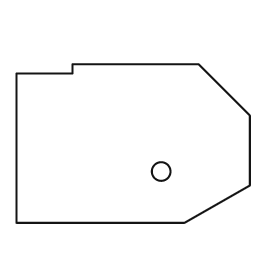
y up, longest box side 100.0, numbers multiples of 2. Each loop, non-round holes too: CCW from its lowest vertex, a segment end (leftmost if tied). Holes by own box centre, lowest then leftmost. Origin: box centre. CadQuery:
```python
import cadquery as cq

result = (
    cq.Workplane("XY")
    .moveTo(-50.0, -34.0)
    .lineTo(22.0, -34.0)
    .lineTo(50.0, -18.0)
    .lineTo(50.0, 12.0)
    .lineTo(28.0, 34.0)
    .lineTo(-26.0, 34.0)
    .lineTo(-26.0, 30.0)
    .lineTo(-50.0, 30.0)
    .close()
    .moveTo(12.0, -12.0)
    .circle(4.0)
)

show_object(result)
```